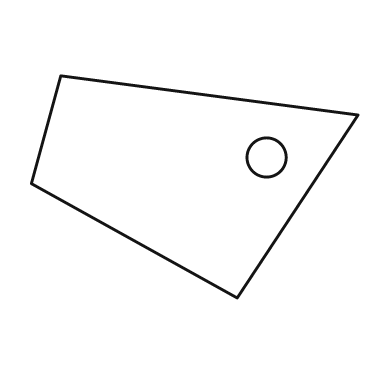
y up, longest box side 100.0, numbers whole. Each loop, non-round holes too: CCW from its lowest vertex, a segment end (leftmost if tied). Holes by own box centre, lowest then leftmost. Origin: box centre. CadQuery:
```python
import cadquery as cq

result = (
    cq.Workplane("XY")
    .moveTo(13.0, -34.0)
    .lineTo(50.0, 22.0)
    .lineTo(-41.0, 34.0)
    .lineTo(-50.0, 1.0)
    .close()
    .moveTo(22.0, 9.0)
    .circle(6.0)
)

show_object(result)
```